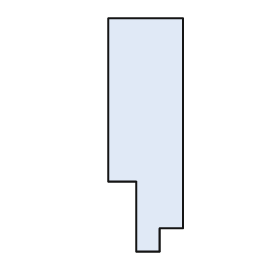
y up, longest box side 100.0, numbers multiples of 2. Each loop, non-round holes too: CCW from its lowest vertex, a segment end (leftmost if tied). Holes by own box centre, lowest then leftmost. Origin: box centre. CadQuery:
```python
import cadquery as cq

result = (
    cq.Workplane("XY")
    .moveTo(-4.0, -50.0)
    .lineTo(6.0, -50.0)
    .lineTo(6.0, -40.0)
    .lineTo(16.0, -40.0)
    .lineTo(16.0, 50.0)
    .lineTo(-16.0, 50.0)
    .lineTo(-16.0, -20.0)
    .lineTo(-4.0, -20.0)
    .close()
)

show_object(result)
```